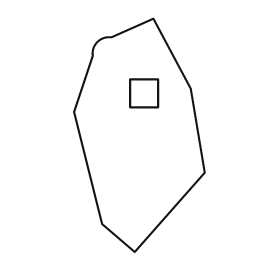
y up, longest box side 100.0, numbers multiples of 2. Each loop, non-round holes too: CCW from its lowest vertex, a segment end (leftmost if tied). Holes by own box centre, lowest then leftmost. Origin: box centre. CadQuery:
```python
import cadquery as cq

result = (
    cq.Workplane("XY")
    .moveTo(-2.0, -50.0)
    .lineTo(28.0, -16.0)
    .lineTo(22.0, 20.0)
    .lineTo(6.0, 50.0)
    .lineTo(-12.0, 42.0)
    .threePointArc((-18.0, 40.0), (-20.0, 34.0))
    .lineTo(-28.0, 10.0)
    .lineTo(-16.0, -38.0)
    .close()
    .moveTo(-4.0, 12.0)
    .lineTo(8.0, 12.0)
    .lineTo(8.0, 24.0)
    .lineTo(-4.0, 24.0)
    .close()
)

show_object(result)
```